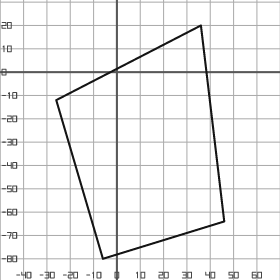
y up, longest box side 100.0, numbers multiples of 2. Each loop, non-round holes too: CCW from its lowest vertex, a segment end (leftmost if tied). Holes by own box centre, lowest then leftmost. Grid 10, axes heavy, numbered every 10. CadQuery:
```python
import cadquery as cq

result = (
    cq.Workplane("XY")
    .moveTo(-6.0, -80.0)
    .lineTo(46.0, -64.0)
    .lineTo(36.0, 20.0)
    .lineTo(-26.0, -12.0)
    .close()
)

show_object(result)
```